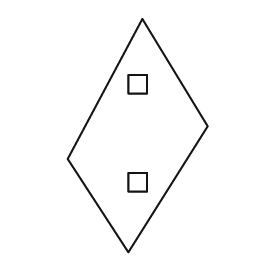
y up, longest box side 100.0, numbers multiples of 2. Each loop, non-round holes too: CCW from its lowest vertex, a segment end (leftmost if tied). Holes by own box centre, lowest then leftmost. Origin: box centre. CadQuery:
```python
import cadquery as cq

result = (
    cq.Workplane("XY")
    .moveTo(-4.0, -50.0)
    .lineTo(30.0, 4.0)
    .lineTo(2.0, 50.0)
    .lineTo(-30.0, -10.0)
    .close()
    .moveTo(-4.0, -24.0)
    .lineTo(4.0, -24.0)
    .lineTo(4.0, -16.0)
    .lineTo(-4.0, -16.0)
    .close()
    .moveTo(-4.0, 18.0)
    .lineTo(4.0, 18.0)
    .lineTo(4.0, 26.0)
    .lineTo(-4.0, 26.0)
    .close()
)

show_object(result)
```